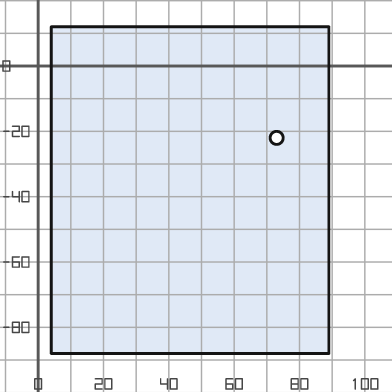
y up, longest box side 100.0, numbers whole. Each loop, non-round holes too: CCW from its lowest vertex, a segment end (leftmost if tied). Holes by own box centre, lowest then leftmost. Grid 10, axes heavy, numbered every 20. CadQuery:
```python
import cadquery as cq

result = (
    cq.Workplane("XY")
    .moveTo(4.0, -88.0)
    .lineTo(89.0, -88.0)
    .lineTo(89.0, 12.0)
    .lineTo(4.0, 12.0)
    .close()
    .moveTo(73.0, -22.0)
    .circle(2.0)
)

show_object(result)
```